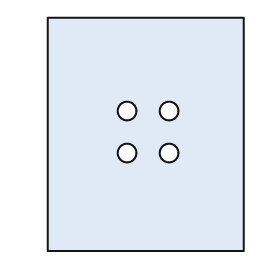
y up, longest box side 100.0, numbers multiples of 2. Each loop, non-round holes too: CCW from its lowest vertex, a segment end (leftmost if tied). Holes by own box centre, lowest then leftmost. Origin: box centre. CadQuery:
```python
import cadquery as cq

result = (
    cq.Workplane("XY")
    .moveTo(-42.0, -50.0)
    .lineTo(42.0, -50.0)
    .lineTo(42.0, 50.0)
    .lineTo(-42.0, 50.0)
    .close()
    .moveTo(-8.0, -8.0)
    .circle(4.0)
    .moveTo(10.0, -8.0)
    .circle(4.0)
    .moveTo(-8.0, 10.0)
    .circle(4.0)
    .moveTo(10.0, 10.0)
    .circle(4.0)
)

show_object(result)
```